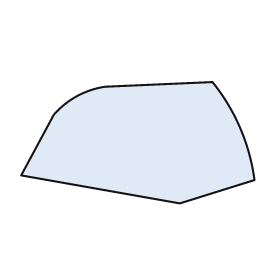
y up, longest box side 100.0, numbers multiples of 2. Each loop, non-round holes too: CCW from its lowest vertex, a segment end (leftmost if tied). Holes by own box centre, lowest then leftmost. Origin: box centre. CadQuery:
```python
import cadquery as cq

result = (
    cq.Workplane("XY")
    .moveTo(18.0, -26.0)
    .lineTo(50.0, -16.0)
    .threePointArc((44.0, 6.0), (32.0, 26.0))
    .lineTo(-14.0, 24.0)
    .threePointArc((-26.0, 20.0), (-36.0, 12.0))
    .lineTo(-50.0, -14.0)
    .close()
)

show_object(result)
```